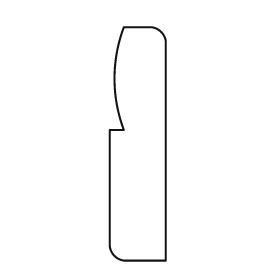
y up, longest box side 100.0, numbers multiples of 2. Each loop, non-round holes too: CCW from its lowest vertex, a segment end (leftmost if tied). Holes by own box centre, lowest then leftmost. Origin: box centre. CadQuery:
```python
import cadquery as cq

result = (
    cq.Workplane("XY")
    .moveTo(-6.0, -50.0)
    .lineTo(12.0, -50.0)
    .lineTo(12.0, 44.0)
    .threePointArc((10.0, 48.0), (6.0, 50.0))
    .lineTo(-6.0, 50.0)
    .threePointArc((-10.0, 28.0), (-6.0, 6.0))
    .lineTo(-12.0, 6.0)
    .lineTo(-12.0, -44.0)
    .threePointArc((-10.0, -48.0), (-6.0, -50.0))
    .close()
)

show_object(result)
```